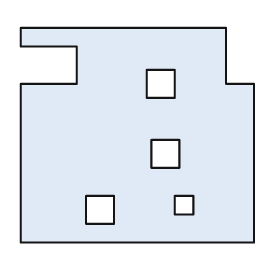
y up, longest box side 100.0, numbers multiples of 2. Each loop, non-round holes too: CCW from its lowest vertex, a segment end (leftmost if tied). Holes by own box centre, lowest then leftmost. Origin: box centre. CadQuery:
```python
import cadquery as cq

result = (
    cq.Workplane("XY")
    .moveTo(-50.0, -46.0)
    .lineTo(50.0, -46.0)
    .lineTo(50.0, 22.0)
    .lineTo(38.0, 22.0)
    .lineTo(38.0, 46.0)
    .lineTo(-50.0, 46.0)
    .lineTo(-50.0, 38.0)
    .lineTo(-26.0, 38.0)
    .lineTo(-26.0, 22.0)
    .lineTo(-50.0, 22.0)
    .close()
    .moveTo(-22.0, -38.0)
    .lineTo(-10.0, -38.0)
    .lineTo(-10.0, -26.0)
    .lineTo(-22.0, -26.0)
    .close()
    .moveTo(16.0, -34.0)
    .lineTo(24.0, -34.0)
    .lineTo(24.0, -26.0)
    .lineTo(16.0, -26.0)
    .close()
    .moveTo(6.0, -14.0)
    .lineTo(18.0, -14.0)
    .lineTo(18.0, -2.0)
    .lineTo(6.0, -2.0)
    .close()
    .moveTo(4.0, 16.0)
    .lineTo(16.0, 16.0)
    .lineTo(16.0, 28.0)
    .lineTo(4.0, 28.0)
    .close()
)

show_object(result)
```